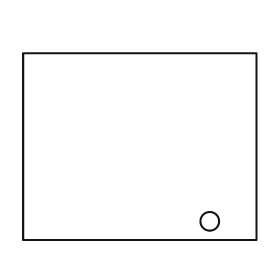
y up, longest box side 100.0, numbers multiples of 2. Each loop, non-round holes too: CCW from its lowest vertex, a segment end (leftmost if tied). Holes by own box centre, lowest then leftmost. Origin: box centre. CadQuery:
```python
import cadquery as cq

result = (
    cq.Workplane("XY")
    .moveTo(-50.0, -40.0)
    .lineTo(50.0, -40.0)
    .lineTo(50.0, 40.0)
    .lineTo(-50.0, 40.0)
    .close()
    .moveTo(30.0, -32.0)
    .circle(4.0)
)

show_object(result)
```